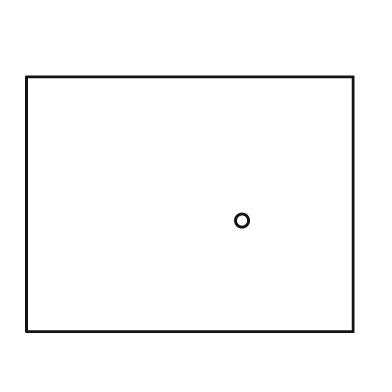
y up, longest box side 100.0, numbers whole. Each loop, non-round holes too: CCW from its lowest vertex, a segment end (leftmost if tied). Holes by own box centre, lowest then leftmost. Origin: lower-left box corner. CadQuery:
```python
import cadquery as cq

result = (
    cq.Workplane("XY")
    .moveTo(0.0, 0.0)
    .lineTo(100.0, 0.0)
    .lineTo(100.0, 78.0)
    .lineTo(0.0, 78.0)
    .close()
    .moveTo(66.0, 34.0)
    .circle(2.0)
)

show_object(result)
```